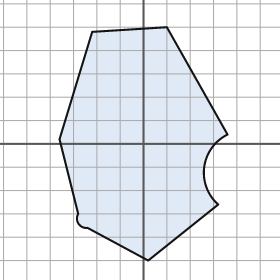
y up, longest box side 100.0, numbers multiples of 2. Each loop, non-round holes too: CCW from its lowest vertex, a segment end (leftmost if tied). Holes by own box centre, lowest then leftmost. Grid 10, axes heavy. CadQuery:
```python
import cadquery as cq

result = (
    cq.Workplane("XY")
    .moveTo(2.0, -50.0)
    .lineTo(32.0, -26.0)
    .threePointArc((26.0, -10.0), (36.0, 4.0))
    .lineTo(10.0, 50.0)
    .lineTo(-22.0, 48.0)
    .lineTo(-36.0, 2.0)
    .lineTo(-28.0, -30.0)
    .threePointArc((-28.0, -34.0), (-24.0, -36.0))
    .close()
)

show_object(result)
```